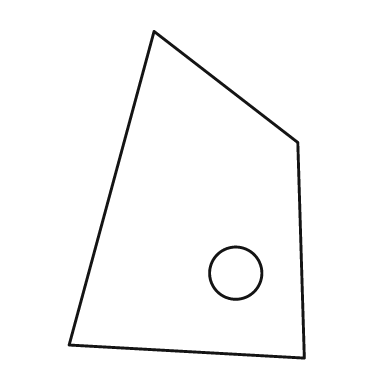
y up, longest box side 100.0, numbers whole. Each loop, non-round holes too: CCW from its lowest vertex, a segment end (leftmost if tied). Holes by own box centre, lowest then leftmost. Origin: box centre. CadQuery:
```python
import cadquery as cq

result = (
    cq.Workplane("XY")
    .moveTo(36.0, -50.0)
    .lineTo(34.0, 16.0)
    .lineTo(-10.0, 50.0)
    .lineTo(-36.0, -46.0)
    .close()
    .moveTo(15.0, -24.0)
    .circle(8.0)
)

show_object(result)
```